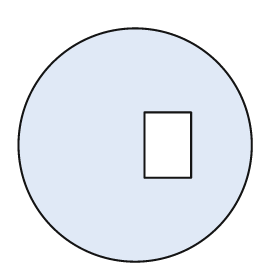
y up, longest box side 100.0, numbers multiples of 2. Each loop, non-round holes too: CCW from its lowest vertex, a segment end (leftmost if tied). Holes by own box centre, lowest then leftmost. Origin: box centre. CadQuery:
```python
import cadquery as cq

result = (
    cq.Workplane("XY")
    .moveTo(0.0, 0.0)
    .circle(50.0)
    .moveTo(4.0, -14.0)
    .lineTo(24.0, -14.0)
    .lineTo(24.0, 14.0)
    .lineTo(4.0, 14.0)
    .close()
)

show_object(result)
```